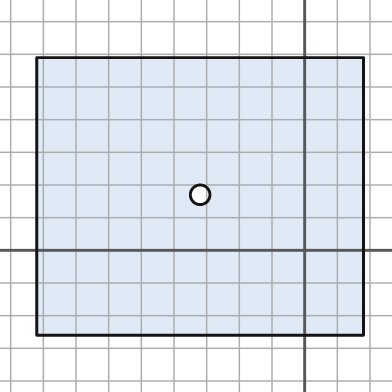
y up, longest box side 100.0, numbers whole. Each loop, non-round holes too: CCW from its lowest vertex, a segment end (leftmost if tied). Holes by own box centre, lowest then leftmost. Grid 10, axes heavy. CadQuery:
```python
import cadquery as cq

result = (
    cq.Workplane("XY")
    .moveTo(-82.0, -26.0)
    .lineTo(18.0, -26.0)
    .lineTo(18.0, 59.0)
    .lineTo(-82.0, 59.0)
    .close()
    .moveTo(-32.0, 17.0)
    .circle(3.0)
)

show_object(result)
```